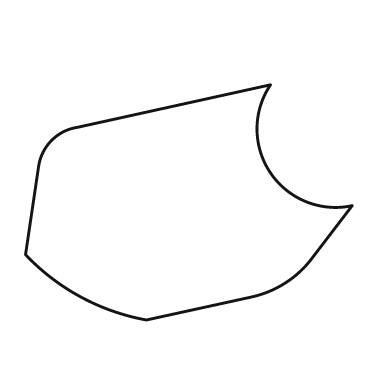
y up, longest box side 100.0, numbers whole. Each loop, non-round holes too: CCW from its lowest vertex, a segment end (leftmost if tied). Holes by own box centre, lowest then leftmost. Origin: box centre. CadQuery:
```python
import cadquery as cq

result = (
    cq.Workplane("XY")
    .moveTo(-13.0, -36.0)
    .lineTo(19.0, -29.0)
    .threePointArc((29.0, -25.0), (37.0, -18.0))
    .lineTo(50.0, -1.0)
    .threePointArc((25.0, 9.0), (25.0, 36.0))
    .lineTo(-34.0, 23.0)
    .threePointArc((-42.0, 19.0), (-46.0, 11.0))
    .lineTo(-50.0, -16.0)
    .threePointArc((-33.0, -29.0), (-13.0, -36.0))
    .close()
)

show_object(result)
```